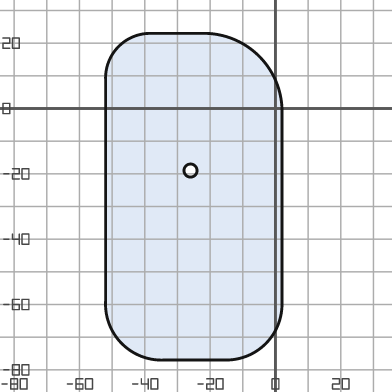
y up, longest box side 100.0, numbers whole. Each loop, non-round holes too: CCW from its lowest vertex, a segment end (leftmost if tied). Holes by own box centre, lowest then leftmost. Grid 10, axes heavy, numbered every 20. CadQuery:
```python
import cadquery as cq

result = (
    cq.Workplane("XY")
    .moveTo(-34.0, -77.0)
    .lineTo(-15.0, -77.0)
    .threePointArc((-3.0, -72.0), (2.0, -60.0))
    .lineTo(2.0, 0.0)
    .threePointArc((-5.0, 16.0), (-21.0, 23.0))
    .lineTo(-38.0, 23.0)
    .threePointArc((-48.0, 19.0), (-52.0, 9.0))
    .lineTo(-52.0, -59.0)
    .threePointArc((-47.0, -72.0), (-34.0, -77.0))
    .close()
    .moveTo(-26.0, -19.0)
    .circle(2.0)
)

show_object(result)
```